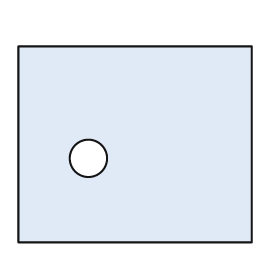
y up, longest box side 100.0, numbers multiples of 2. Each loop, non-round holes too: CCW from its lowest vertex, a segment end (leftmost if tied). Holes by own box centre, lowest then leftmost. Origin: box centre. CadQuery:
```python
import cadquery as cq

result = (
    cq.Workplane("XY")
    .moveTo(-50.0, -42.0)
    .lineTo(50.0, -42.0)
    .lineTo(50.0, 42.0)
    .lineTo(-50.0, 42.0)
    .close()
    .moveTo(-20.0, -6.0)
    .circle(8.0)
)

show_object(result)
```